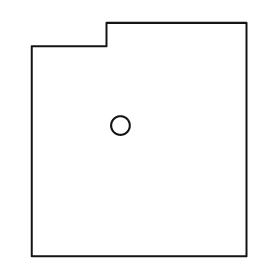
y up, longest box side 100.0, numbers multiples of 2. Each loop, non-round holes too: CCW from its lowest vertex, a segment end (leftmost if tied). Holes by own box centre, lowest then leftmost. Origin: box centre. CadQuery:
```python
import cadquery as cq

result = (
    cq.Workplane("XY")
    .moveTo(-46.0, -50.0)
    .lineTo(46.0, -50.0)
    .lineTo(46.0, 50.0)
    .lineTo(-14.0, 50.0)
    .lineTo(-14.0, 40.0)
    .lineTo(-46.0, 40.0)
    .close()
    .moveTo(-8.0, 6.0)
    .circle(4.0)
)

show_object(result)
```